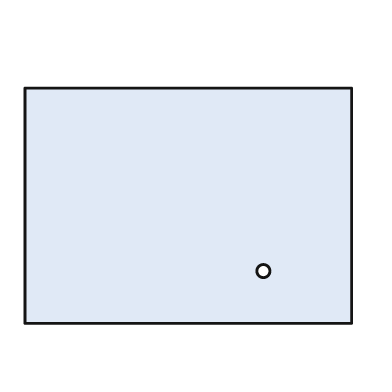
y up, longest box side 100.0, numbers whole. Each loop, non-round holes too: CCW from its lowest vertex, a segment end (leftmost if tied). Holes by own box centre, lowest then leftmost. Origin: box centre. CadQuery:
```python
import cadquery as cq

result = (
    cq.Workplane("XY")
    .moveTo(-50.0, -36.0)
    .lineTo(50.0, -36.0)
    .lineTo(50.0, 36.0)
    .lineTo(-50.0, 36.0)
    .close()
    .moveTo(23.0, -20.0)
    .circle(2.0)
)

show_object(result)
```